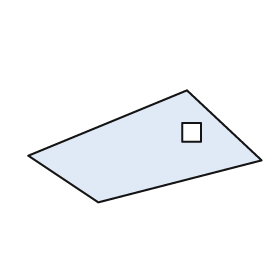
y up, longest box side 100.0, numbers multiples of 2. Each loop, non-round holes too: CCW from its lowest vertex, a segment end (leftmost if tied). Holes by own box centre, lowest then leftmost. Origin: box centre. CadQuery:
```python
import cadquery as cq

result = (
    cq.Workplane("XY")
    .moveTo(-20.0, -24.0)
    .lineTo(50.0, -6.0)
    .lineTo(18.0, 24.0)
    .lineTo(-50.0, -4.0)
    .close()
    .moveTo(16.0, 2.0)
    .lineTo(24.0, 2.0)
    .lineTo(24.0, 10.0)
    .lineTo(16.0, 10.0)
    .close()
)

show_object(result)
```